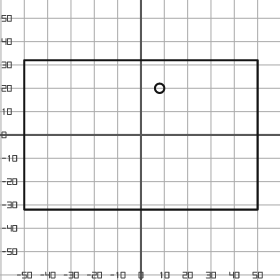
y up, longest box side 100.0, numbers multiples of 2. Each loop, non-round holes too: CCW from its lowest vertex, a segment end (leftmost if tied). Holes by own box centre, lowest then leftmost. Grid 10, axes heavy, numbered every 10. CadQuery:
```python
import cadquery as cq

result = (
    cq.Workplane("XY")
    .moveTo(-50.0, -32.0)
    .lineTo(50.0, -32.0)
    .lineTo(50.0, 32.0)
    .lineTo(-50.0, 32.0)
    .close()
    .moveTo(8.0, 20.0)
    .circle(2.0)
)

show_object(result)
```